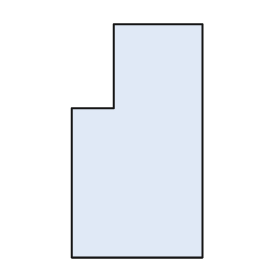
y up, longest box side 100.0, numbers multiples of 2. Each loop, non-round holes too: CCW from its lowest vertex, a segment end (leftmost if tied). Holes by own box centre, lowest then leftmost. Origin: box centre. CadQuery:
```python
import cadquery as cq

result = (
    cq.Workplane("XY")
    .moveTo(-28.0, -50.0)
    .lineTo(28.0, -50.0)
    .lineTo(28.0, 50.0)
    .lineTo(-10.0, 50.0)
    .lineTo(-10.0, 14.0)
    .lineTo(-28.0, 14.0)
    .close()
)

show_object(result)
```